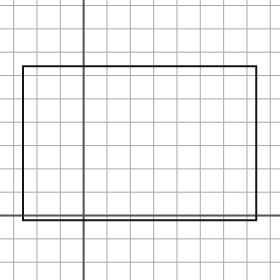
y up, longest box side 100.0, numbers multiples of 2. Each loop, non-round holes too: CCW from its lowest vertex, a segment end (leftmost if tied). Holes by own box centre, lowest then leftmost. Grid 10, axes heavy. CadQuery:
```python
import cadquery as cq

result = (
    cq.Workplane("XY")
    .moveTo(-26.0, -2.0)
    .lineTo(74.0, -2.0)
    .lineTo(74.0, 64.0)
    .lineTo(-26.0, 64.0)
    .close()
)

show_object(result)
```